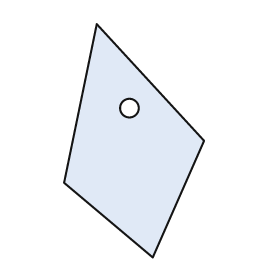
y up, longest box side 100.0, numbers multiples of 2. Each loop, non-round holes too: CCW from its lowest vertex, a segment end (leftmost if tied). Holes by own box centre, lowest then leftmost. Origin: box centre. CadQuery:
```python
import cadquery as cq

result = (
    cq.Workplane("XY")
    .moveTo(8.0, -50.0)
    .lineTo(30.0, 0.0)
    .lineTo(-16.0, 50.0)
    .lineTo(-30.0, -18.0)
    .close()
    .moveTo(-2.0, 14.0)
    .circle(4.0)
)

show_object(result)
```